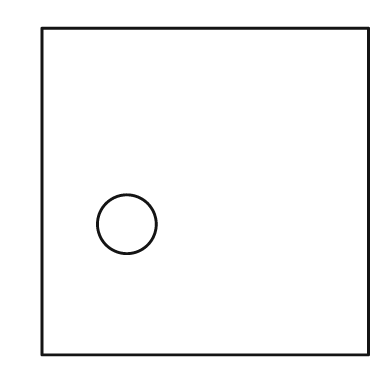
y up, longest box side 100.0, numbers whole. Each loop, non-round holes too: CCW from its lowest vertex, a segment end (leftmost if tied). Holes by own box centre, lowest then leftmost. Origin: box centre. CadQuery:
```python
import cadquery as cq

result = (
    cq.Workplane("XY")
    .moveTo(-50.0, -50.0)
    .lineTo(50.0, -50.0)
    .lineTo(50.0, 50.0)
    .lineTo(-50.0, 50.0)
    .close()
    .moveTo(-24.0, -10.0)
    .circle(9.0)
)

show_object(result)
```